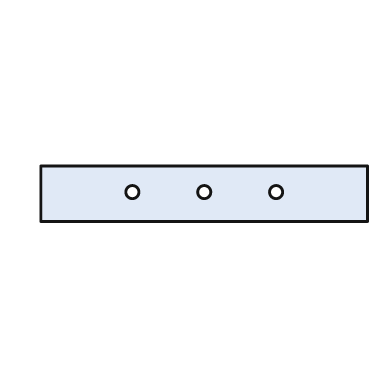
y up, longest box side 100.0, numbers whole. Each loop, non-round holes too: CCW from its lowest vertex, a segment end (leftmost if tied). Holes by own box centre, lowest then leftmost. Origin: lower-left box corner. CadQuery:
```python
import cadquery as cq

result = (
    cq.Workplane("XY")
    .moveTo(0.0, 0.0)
    .lineTo(100.0, 0.0)
    .lineTo(100.0, 17.0)
    .lineTo(0.0, 17.0)
    .close()
    .moveTo(28.0, 9.0)
    .circle(2.0)
    .moveTo(50.0, 9.0)
    .circle(2.0)
    .moveTo(72.0, 9.0)
    .circle(2.0)
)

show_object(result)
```